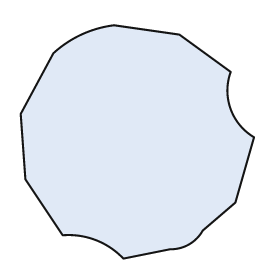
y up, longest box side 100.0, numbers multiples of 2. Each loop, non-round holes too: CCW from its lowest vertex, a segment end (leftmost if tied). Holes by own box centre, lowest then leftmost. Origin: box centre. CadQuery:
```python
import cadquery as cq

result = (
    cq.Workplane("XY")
    .moveTo(-6.0, -50.0)
    .lineTo(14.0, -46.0)
    .threePointArc((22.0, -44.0), (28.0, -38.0))
    .lineTo(42.0, -26.0)
    .lineTo(50.0, 2.0)
    .threePointArc((40.0, 14.0), (40.0, 30.0))
    .lineTo(18.0, 46.0)
    .lineTo(-10.0, 50.0)
    .threePointArc((-24.0, 46.0), (-36.0, 38.0))
    .lineTo(-50.0, 12.0)
    .lineTo(-48.0, -16.0)
    .lineTo(-32.0, -40.0)
    .threePointArc((-18.0, -42.0), (-6.0, -50.0))
    .close()
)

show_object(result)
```